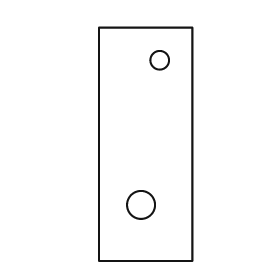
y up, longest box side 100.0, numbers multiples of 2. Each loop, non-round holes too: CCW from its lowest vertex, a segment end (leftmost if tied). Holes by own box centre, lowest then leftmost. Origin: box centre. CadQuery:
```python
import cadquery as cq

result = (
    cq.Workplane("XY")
    .moveTo(-20.0, -50.0)
    .lineTo(20.0, -50.0)
    .lineTo(20.0, 50.0)
    .lineTo(-20.0, 50.0)
    .close()
    .moveTo(-2.0, -26.0)
    .circle(6.0)
    .moveTo(6.0, 36.0)
    .circle(4.0)
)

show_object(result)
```